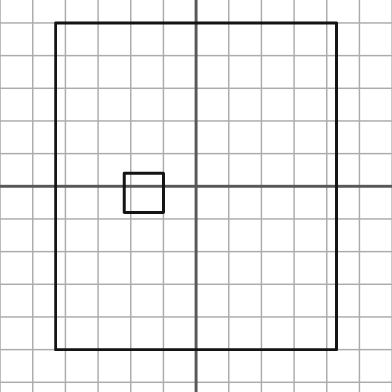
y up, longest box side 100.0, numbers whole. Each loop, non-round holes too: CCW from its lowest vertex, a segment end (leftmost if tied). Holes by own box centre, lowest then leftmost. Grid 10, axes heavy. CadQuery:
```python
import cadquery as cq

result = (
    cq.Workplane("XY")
    .moveTo(-43.0, -50.0)
    .lineTo(43.0, -50.0)
    .lineTo(43.0, 50.0)
    .lineTo(-43.0, 50.0)
    .close()
    .moveTo(-22.0, -8.0)
    .lineTo(-10.0, -8.0)
    .lineTo(-10.0, 4.0)
    .lineTo(-22.0, 4.0)
    .close()
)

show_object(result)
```